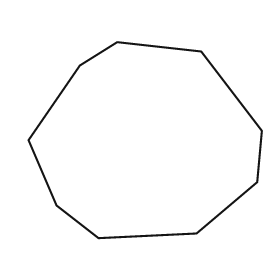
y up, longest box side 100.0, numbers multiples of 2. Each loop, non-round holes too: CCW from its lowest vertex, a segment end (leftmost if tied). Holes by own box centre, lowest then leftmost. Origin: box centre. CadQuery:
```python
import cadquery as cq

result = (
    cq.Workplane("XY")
    .moveTo(-20.0, -42.0)
    .lineTo(22.0, -40.0)
    .lineTo(48.0, -18.0)
    .lineTo(50.0, 4.0)
    .lineTo(24.0, 38.0)
    .lineTo(-12.0, 42.0)
    .lineTo(-28.0, 32.0)
    .lineTo(-50.0, 0.0)
    .lineTo(-38.0, -28.0)
    .close()
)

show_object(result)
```